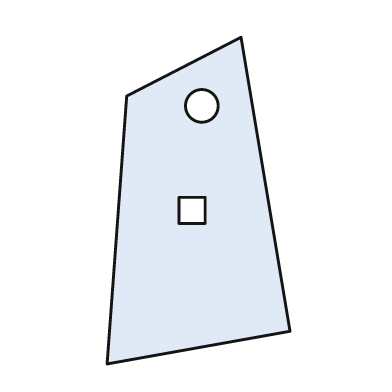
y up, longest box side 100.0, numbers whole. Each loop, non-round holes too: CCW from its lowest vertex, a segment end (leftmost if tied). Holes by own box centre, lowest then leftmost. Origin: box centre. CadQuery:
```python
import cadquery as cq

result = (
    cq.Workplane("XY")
    .moveTo(-28.0, -50.0)
    .lineTo(28.0, -40.0)
    .lineTo(13.0, 50.0)
    .lineTo(-22.0, 32.0)
    .close()
    .moveTo(-6.0, -7.0)
    .lineTo(2.0, -7.0)
    .lineTo(2.0, 1.0)
    .lineTo(-6.0, 1.0)
    .close()
    .moveTo(1.0, 29.0)
    .circle(5.0)
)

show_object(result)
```